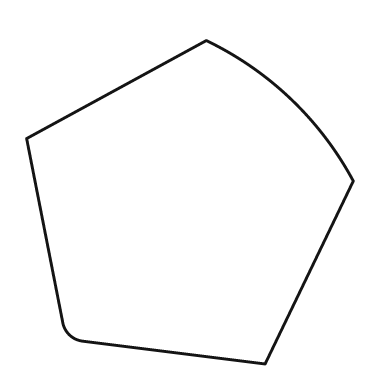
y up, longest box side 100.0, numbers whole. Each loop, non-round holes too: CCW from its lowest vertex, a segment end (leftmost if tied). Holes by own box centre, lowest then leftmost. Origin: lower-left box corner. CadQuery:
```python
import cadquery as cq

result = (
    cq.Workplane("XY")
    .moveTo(73.0, 0.0)
    .lineTo(100.0, 56.0)
    .threePointArc((81.0, 81.0), (55.0, 99.0))
    .lineTo(0.0, 69.0)
    .lineTo(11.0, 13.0)
    .threePointArc((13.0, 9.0), (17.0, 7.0))
    .close()
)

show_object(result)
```